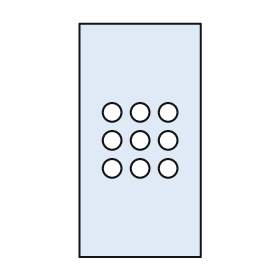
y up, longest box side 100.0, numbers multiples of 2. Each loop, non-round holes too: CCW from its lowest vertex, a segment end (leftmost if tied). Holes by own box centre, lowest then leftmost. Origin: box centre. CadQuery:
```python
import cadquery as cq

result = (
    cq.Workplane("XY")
    .moveTo(-26.0, -50.0)
    .lineTo(26.0, -50.0)
    .lineTo(26.0, 50.0)
    .lineTo(-26.0, 50.0)
    .close()
    .moveTo(-12.0, -12.0)
    .circle(4.0)
    .moveTo(0.0, -12.0)
    .circle(4.0)
    .moveTo(12.0, -12.0)
    .circle(4.0)
    .moveTo(-12.0, 0.0)
    .circle(4.0)
    .moveTo(0.0, 0.0)
    .circle(4.0)
    .moveTo(12.0, 0.0)
    .circle(4.0)
    .moveTo(-12.0, 12.0)
    .circle(4.0)
    .moveTo(0.0, 12.0)
    .circle(4.0)
    .moveTo(12.0, 12.0)
    .circle(4.0)
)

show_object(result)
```